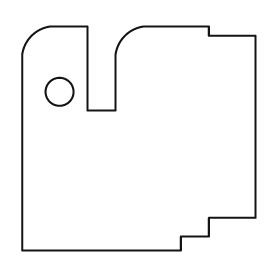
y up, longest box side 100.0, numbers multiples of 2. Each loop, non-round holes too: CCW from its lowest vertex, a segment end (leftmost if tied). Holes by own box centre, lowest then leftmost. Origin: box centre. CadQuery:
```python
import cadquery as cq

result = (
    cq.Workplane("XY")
    .moveTo(-50.0, -48.0)
    .lineTo(18.0, -48.0)
    .lineTo(18.0, -42.0)
    .lineTo(30.0, -42.0)
    .lineTo(30.0, -34.0)
    .lineTo(50.0, -34.0)
    .lineTo(50.0, 44.0)
    .lineTo(30.0, 44.0)
    .lineTo(30.0, 48.0)
    .lineTo(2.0, 48.0)
    .threePointArc((-6.0, 44.0), (-10.0, 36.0))
    .lineTo(-10.0, 12.0)
    .lineTo(-22.0, 12.0)
    .lineTo(-22.0, 48.0)
    .lineTo(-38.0, 48.0)
    .threePointArc((-46.0, 44.0), (-50.0, 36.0))
    .close()
    .moveTo(-34.0, 20.0)
    .circle(6.0)
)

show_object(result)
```